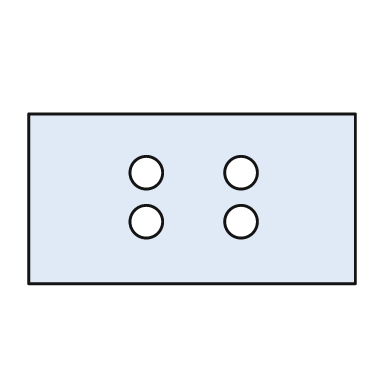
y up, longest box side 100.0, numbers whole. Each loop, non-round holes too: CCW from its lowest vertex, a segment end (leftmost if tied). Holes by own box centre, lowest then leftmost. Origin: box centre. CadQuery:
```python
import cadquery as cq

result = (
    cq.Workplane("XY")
    .moveTo(-50.0, -26.0)
    .lineTo(50.0, -26.0)
    .lineTo(50.0, 26.0)
    .lineTo(-50.0, 26.0)
    .close()
    .moveTo(-14.0, -7.0)
    .circle(5.0)
    .moveTo(15.0, -7.0)
    .circle(5.0)
    .moveTo(-14.0, 8.0)
    .circle(5.0)
    .moveTo(15.0, 8.0)
    .circle(5.0)
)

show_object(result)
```